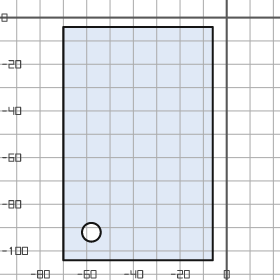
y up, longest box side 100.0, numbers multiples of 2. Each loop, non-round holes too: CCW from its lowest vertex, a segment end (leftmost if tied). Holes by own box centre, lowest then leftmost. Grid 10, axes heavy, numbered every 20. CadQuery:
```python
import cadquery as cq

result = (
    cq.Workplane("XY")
    .moveTo(-70.0, -104.0)
    .lineTo(-6.0, -104.0)
    .lineTo(-6.0, -4.0)
    .lineTo(-70.0, -4.0)
    .close()
    .moveTo(-58.0, -92.0)
    .circle(4.0)
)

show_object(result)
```